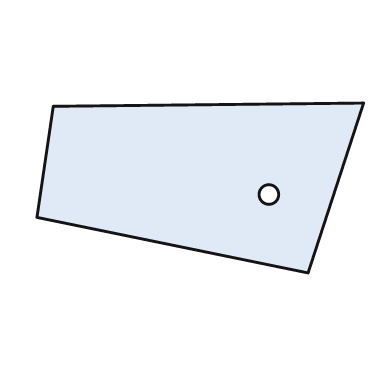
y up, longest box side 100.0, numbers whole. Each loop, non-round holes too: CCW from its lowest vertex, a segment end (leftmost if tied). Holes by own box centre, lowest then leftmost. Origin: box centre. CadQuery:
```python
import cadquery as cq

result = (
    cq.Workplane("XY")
    .moveTo(33.0, -26.0)
    .lineTo(50.0, 26.0)
    .lineTo(-45.0, 25.0)
    .lineTo(-50.0, -9.0)
    .close()
    .moveTo(21.0, -2.0)
    .circle(3.0)
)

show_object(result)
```